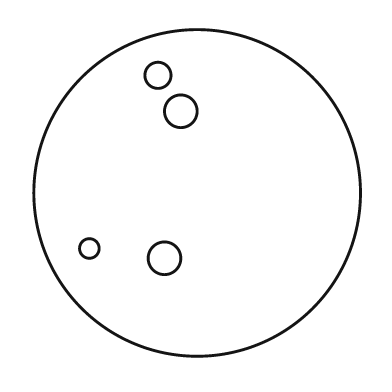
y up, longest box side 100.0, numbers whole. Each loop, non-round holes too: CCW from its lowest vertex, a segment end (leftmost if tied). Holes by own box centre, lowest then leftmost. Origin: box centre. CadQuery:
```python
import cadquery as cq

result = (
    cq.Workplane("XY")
    .moveTo(0.0, 0.0)
    .circle(50.0)
    .moveTo(-10.0, -20.0)
    .circle(5.0)
    .moveTo(-33.0, -17.0)
    .circle(3.0)
    .moveTo(-5.0, 25.0)
    .circle(5.0)
    .moveTo(-12.0, 36.0)
    .circle(4.0)
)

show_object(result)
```